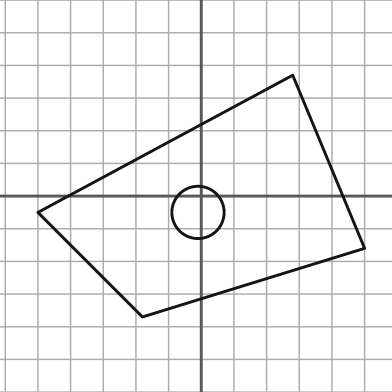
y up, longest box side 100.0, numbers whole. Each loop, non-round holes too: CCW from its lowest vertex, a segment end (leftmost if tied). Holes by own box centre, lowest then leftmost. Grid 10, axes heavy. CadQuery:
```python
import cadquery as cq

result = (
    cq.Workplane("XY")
    .moveTo(-18.0, -37.0)
    .lineTo(50.0, -16.0)
    .lineTo(28.0, 37.0)
    .lineTo(-50.0, -5.0)
    .close()
    .moveTo(-1.0, -5.0)
    .circle(8.0)
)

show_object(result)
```